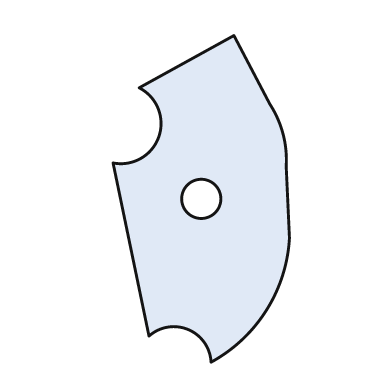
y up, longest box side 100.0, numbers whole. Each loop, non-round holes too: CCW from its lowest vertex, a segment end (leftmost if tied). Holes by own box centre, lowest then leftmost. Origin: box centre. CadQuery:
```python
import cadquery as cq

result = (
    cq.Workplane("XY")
    .moveTo(3.0, -50.0)
    .threePointArc((20.0, -34.0), (27.0, -12.0))
    .lineTo(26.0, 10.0)
    .threePointArc((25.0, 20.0), (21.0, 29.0))
    .lineTo(10.0, 50.0)
    .lineTo(-19.0, 34.0)
    .threePointArc((-13.0, 19.0), (-27.0, 11.0))
    .lineTo(-16.0, -42.0)
    .threePointArc((-4.0, -40.0), (3.0, -50.0))
    .close()
    .moveTo(0.0, 0.0)
    .circle(6.0)
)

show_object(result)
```